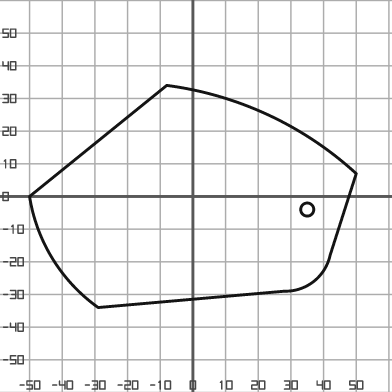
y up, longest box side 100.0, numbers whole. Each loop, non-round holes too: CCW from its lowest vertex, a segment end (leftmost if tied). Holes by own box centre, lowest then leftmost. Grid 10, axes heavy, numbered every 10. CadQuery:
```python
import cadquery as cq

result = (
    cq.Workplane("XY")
    .moveTo(-29.0, -34.0)
    .lineTo(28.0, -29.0)
    .threePointArc((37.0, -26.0), (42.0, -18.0))
    .lineTo(50.0, 7.0)
    .threePointArc((23.0, 25.0), (-8.0, 34.0))
    .lineTo(-50.0, 0.0)
    .threePointArc((-43.0, -19.0), (-29.0, -34.0))
    .close()
    .moveTo(35.0, -4.0)
    .circle(2.0)
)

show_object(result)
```